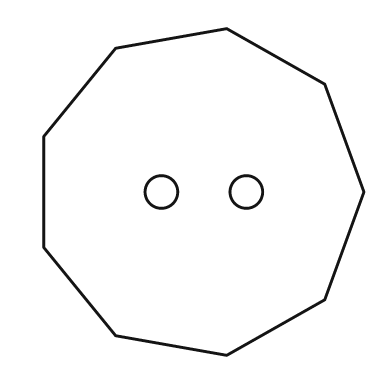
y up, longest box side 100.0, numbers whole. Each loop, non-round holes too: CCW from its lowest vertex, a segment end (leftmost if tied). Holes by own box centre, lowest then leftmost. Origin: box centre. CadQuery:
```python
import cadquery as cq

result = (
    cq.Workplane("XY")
    .moveTo(7.0, -50.0)
    .lineTo(37.0, -33.0)
    .lineTo(49.0, 0.0)
    .lineTo(37.0, 33.0)
    .lineTo(7.0, 50.0)
    .lineTo(-27.0, 44.0)
    .lineTo(-49.0, 17.0)
    .lineTo(-49.0, -17.0)
    .lineTo(-27.0, -44.0)
    .close()
    .moveTo(-13.0, 0.0)
    .circle(5.0)
    .moveTo(13.0, 0.0)
    .circle(5.0)
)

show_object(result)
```